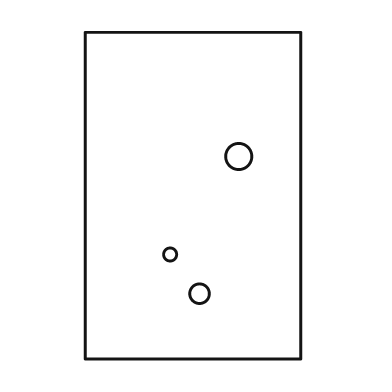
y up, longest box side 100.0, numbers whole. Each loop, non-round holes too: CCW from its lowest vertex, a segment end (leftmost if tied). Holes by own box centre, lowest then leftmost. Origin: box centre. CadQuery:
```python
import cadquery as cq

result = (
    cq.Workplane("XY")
    .moveTo(-33.0, -50.0)
    .lineTo(33.0, -50.0)
    .lineTo(33.0, 50.0)
    .lineTo(-33.0, 50.0)
    .close()
    .moveTo(2.0, -30.0)
    .circle(3.0)
    .moveTo(-7.0, -18.0)
    .circle(2.0)
    .moveTo(14.0, 12.0)
    .circle(4.0)
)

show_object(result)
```